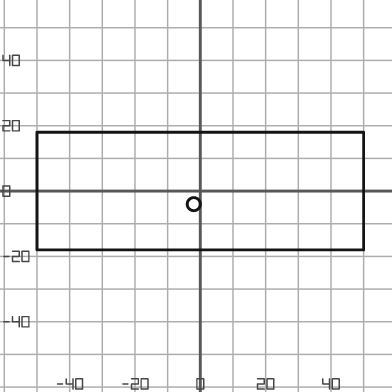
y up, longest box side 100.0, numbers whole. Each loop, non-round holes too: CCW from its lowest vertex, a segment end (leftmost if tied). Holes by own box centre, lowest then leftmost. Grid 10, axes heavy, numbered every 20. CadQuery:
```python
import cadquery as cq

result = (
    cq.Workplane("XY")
    .moveTo(-50.0, -18.0)
    .lineTo(50.0, -18.0)
    .lineTo(50.0, 18.0)
    .lineTo(-50.0, 18.0)
    .close()
    .moveTo(-2.0, -4.0)
    .circle(2.0)
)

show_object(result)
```